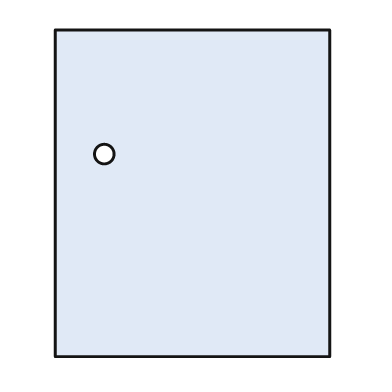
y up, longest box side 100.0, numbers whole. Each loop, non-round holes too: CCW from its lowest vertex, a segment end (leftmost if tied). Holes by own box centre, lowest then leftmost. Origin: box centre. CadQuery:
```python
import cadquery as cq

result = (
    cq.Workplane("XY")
    .moveTo(-42.0, -50.0)
    .lineTo(42.0, -50.0)
    .lineTo(42.0, 50.0)
    .lineTo(-42.0, 50.0)
    .close()
    .moveTo(-27.0, 12.0)
    .circle(3.0)
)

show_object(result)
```